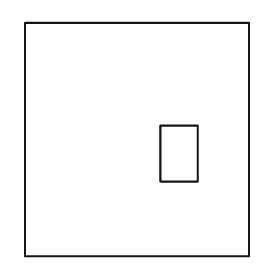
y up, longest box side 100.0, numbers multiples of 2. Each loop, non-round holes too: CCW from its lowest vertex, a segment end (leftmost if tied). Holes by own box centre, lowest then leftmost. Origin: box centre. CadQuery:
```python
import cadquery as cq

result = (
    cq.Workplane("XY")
    .moveTo(-48.0, -50.0)
    .lineTo(48.0, -50.0)
    .lineTo(48.0, 50.0)
    .lineTo(-48.0, 50.0)
    .close()
    .moveTo(10.0, -18.0)
    .lineTo(26.0, -18.0)
    .lineTo(26.0, 6.0)
    .lineTo(10.0, 6.0)
    .close()
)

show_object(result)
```